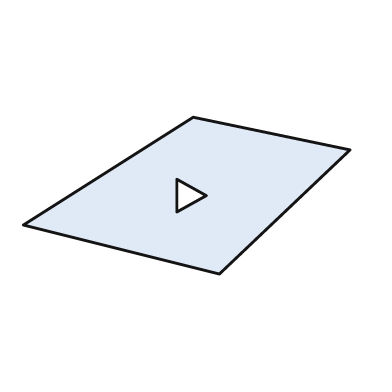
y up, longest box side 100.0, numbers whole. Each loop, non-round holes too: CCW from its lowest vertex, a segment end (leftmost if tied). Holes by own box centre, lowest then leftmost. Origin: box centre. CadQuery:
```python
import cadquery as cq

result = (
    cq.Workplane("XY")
    .moveTo(10.0, -24.0)
    .lineTo(50.0, 14.0)
    .lineTo(2.0, 24.0)
    .lineTo(-50.0, -9.0)
    .close()
    .moveTo(-3.0, -5.0)
    .lineTo(6.0, 0.0)
    .lineTo(-3.0, 5.0)
    .close()
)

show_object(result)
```